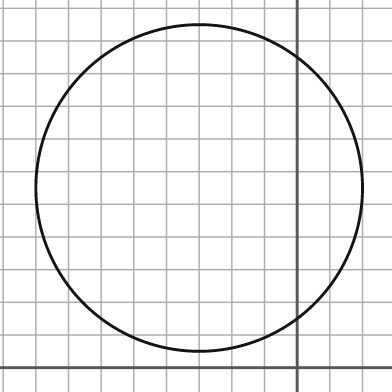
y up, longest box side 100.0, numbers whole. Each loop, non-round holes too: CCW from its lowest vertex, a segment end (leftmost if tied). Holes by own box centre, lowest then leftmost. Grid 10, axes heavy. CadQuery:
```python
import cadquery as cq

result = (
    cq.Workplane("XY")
    .moveTo(-30.0, 55.0)
    .circle(50.0)
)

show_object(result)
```